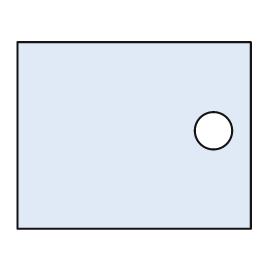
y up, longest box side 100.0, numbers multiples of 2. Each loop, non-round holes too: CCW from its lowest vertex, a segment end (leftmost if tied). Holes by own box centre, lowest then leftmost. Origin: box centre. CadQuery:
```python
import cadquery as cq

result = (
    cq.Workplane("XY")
    .moveTo(-50.0, -40.0)
    .lineTo(50.0, -40.0)
    .lineTo(50.0, 40.0)
    .lineTo(-50.0, 40.0)
    .close()
    .moveTo(34.0, 2.0)
    .circle(8.0)
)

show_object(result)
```